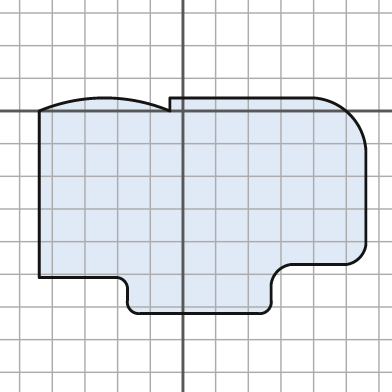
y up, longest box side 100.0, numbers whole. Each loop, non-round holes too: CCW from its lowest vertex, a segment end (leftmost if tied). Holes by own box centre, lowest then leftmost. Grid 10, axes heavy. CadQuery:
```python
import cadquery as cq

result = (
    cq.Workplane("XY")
    .moveTo(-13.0, -62.0)
    .lineTo(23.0, -62.0)
    .threePointArc((26.0, -61.0), (27.0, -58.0))
    .lineTo(27.0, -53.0)
    .threePointArc((29.0, -49.0), (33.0, -47.0))
    .lineTo(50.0, -47.0)
    .threePointArc((54.0, -45.0), (56.0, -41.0))
    .lineTo(56.0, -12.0)
    .threePointArc((51.0, -1.0), (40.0, 4.0))
    .lineTo(-4.0, 4.0)
    .lineTo(-4.0, 0.0)
    .threePointArc((-24.0, 4.0), (-44.0, 0.0))
    .lineTo(-44.0, -51.0)
    .lineTo(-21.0, -51.0)
    .threePointArc((-18.0, -52.0), (-17.0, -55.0))
    .lineTo(-17.0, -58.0)
    .threePointArc((-16.0, -61.0), (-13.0, -62.0))
    .close()
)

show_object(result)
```